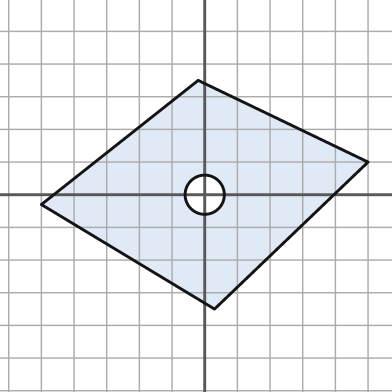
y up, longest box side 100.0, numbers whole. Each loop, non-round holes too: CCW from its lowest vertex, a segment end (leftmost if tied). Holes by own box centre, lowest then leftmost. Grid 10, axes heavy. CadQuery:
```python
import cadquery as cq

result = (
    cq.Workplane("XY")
    .moveTo(3.0, -35.0)
    .lineTo(50.0, 10.0)
    .lineTo(-2.0, 35.0)
    .lineTo(-50.0, -3.0)
    .close()
    .moveTo(0.0, 0.0)
    .circle(6.0)
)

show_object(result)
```